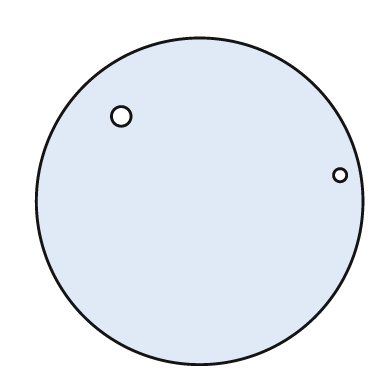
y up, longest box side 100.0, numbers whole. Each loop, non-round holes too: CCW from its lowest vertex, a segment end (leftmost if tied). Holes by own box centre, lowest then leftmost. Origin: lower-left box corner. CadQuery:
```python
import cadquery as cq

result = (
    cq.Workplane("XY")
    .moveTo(50.0, 50.0)
    .circle(50.0)
    .moveTo(93.0, 58.0)
    .circle(2.0)
    .moveTo(26.0, 76.0)
    .circle(3.0)
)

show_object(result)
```